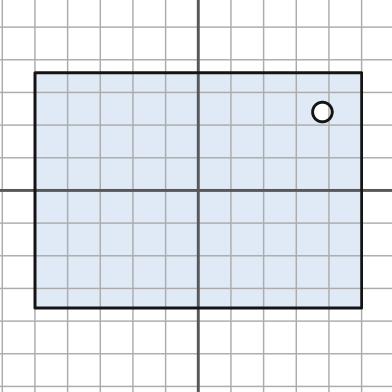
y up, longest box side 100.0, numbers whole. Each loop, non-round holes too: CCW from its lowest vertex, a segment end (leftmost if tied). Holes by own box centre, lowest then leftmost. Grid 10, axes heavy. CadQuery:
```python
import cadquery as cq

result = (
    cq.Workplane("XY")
    .moveTo(-50.0, -36.0)
    .lineTo(50.0, -36.0)
    .lineTo(50.0, 36.0)
    .lineTo(-50.0, 36.0)
    .close()
    .moveTo(38.0, 24.0)
    .circle(3.0)
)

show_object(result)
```